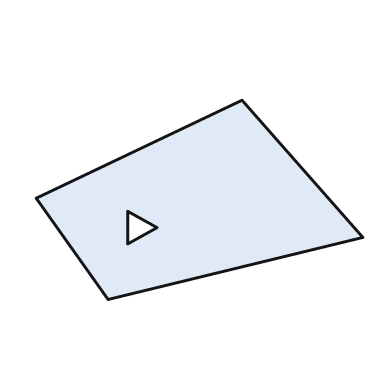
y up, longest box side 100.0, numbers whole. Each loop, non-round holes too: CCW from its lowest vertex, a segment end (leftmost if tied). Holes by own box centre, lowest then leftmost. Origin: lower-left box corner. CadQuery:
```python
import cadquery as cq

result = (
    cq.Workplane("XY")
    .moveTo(22.0, 0.0)
    .lineTo(100.0, 19.0)
    .lineTo(63.0, 61.0)
    .lineTo(0.0, 31.0)
    .close()
    .moveTo(28.0, 17.0)
    .lineTo(37.0, 22.0)
    .lineTo(28.0, 27.0)
    .close()
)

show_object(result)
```